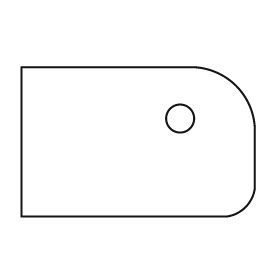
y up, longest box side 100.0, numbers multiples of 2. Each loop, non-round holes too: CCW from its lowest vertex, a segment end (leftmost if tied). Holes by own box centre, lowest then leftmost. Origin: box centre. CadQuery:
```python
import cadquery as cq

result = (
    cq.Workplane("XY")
    .moveTo(-50.0, -32.0)
    .lineTo(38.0, -32.0)
    .threePointArc((46.0, -28.0), (50.0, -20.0))
    .lineTo(50.0, 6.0)
    .threePointArc((42.0, 24.0), (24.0, 32.0))
    .lineTo(-50.0, 32.0)
    .close()
    .moveTo(18.0, 10.0)
    .circle(6.0)
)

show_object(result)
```